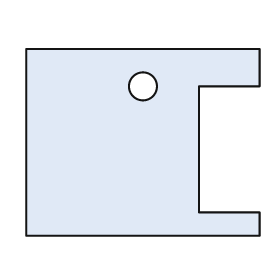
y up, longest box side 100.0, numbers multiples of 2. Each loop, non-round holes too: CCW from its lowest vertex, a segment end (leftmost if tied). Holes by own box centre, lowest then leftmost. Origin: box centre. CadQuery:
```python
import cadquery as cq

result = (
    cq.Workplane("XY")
    .moveTo(-50.0, -40.0)
    .lineTo(50.0, -40.0)
    .lineTo(50.0, -30.0)
    .lineTo(24.0, -30.0)
    .lineTo(24.0, 24.0)
    .lineTo(50.0, 24.0)
    .lineTo(50.0, 40.0)
    .lineTo(-50.0, 40.0)
    .close()
    .moveTo(0.0, 24.0)
    .circle(6.0)
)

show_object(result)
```